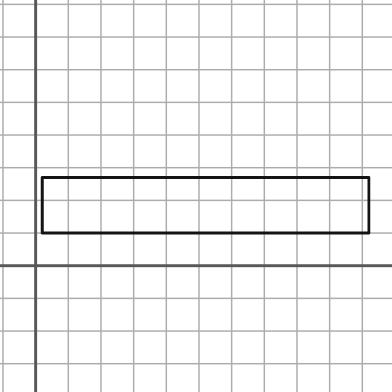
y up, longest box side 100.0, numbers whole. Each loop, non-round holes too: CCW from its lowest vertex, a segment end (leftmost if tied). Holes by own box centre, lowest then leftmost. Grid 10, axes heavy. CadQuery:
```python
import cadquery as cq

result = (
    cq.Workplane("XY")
    .moveTo(2.0, 10.0)
    .lineTo(102.0, 10.0)
    .lineTo(102.0, 27.0)
    .lineTo(2.0, 27.0)
    .close()
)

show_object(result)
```